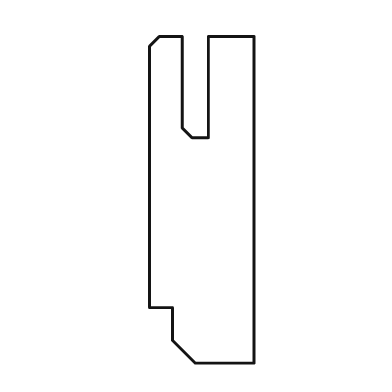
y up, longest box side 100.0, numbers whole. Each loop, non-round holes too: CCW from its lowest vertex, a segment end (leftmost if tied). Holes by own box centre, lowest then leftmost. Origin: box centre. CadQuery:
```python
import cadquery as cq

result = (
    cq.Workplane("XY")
    .moveTo(-2.0, -50.0)
    .lineTo(16.0, -50.0)
    .lineTo(16.0, 50.0)
    .lineTo(2.0, 50.0)
    .lineTo(2.0, 19.0)
    .lineTo(-3.0, 19.0)
    .lineTo(-6.0, 22.0)
    .lineTo(-6.0, 50.0)
    .lineTo(-13.0, 50.0)
    .lineTo(-16.0, 47.0)
    .lineTo(-16.0, -33.0)
    .lineTo(-9.0, -33.0)
    .lineTo(-9.0, -43.0)
    .close()
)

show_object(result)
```